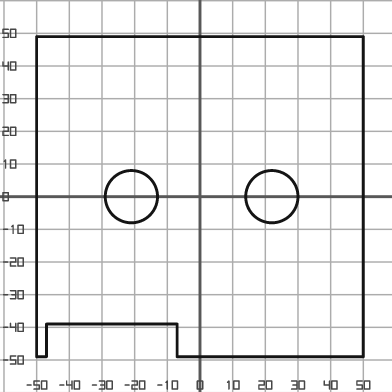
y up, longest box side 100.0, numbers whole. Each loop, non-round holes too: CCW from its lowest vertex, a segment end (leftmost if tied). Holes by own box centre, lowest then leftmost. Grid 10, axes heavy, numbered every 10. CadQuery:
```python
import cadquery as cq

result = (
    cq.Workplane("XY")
    .moveTo(-50.0, -49.0)
    .lineTo(-47.0, -49.0)
    .lineTo(-47.0, -39.0)
    .lineTo(-7.0, -39.0)
    .lineTo(-7.0, -49.0)
    .lineTo(50.0, -49.0)
    .lineTo(50.0, 49.0)
    .lineTo(-50.0, 49.0)
    .close()
    .moveTo(-21.0, 0.0)
    .circle(8.0)
    .moveTo(22.0, 0.0)
    .circle(8.0)
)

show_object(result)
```